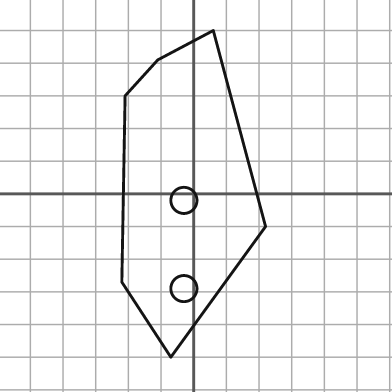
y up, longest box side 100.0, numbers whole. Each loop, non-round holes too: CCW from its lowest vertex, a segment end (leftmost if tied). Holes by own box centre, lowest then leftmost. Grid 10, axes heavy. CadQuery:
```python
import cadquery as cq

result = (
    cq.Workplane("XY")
    .moveTo(-7.0, -50.0)
    .lineTo(22.0, -10.0)
    .lineTo(6.0, 50.0)
    .lineTo(-11.0, 41.0)
    .lineTo(-21.0, 30.0)
    .lineTo(-22.0, -27.0)
    .close()
    .moveTo(-3.0, -29.0)
    .circle(4.0)
    .moveTo(-3.0, -2.0)
    .circle(4.0)
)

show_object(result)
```